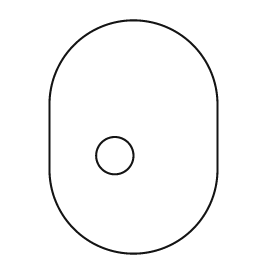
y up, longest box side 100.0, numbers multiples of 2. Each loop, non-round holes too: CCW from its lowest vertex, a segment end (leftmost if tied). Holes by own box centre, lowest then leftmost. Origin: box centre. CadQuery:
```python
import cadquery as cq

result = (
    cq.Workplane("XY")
    .moveTo(-36.0, -14.0)
    .threePointArc((0.0, -50.0), (36.0, -14.0))
    .lineTo(36.0, 14.0)
    .threePointArc((0.0, 50.0), (-36.0, 14.0))
    .close()
    .moveTo(-8.0, -8.0)
    .circle(8.0)
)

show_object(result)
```